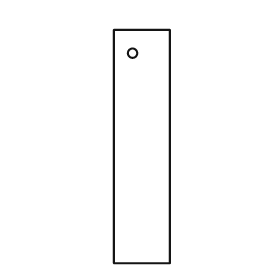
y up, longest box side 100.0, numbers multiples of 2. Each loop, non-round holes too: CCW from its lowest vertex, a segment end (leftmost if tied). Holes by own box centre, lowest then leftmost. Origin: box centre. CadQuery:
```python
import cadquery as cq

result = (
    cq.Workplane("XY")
    .moveTo(-12.0, -50.0)
    .lineTo(12.0, -50.0)
    .lineTo(12.0, 50.0)
    .lineTo(-12.0, 50.0)
    .close()
    .moveTo(-4.0, 40.0)
    .circle(2.0)
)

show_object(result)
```